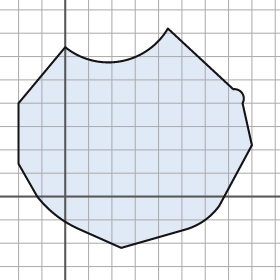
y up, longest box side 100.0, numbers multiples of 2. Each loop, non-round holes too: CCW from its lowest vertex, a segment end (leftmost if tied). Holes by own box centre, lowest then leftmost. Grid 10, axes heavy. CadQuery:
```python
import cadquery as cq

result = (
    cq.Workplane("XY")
    .moveTo(24.0, -22.0)
    .lineTo(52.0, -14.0)
    .threePointArc((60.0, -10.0), (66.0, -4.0))
    .lineTo(80.0, 22.0)
    .lineTo(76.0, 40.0)
    .threePointArc((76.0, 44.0), (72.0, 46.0))
    .lineTo(44.0, 72.0)
    .threePointArc((24.0, 58.0), (0.0, 64.0))
    .lineTo(-20.0, 40.0)
    .lineTo(-20.0, 14.0)
    .lineTo(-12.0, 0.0)
    .threePointArc((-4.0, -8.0), (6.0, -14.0))
    .close()
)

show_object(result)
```